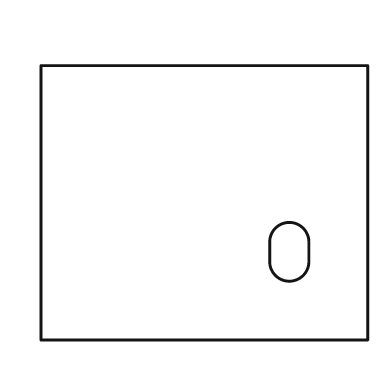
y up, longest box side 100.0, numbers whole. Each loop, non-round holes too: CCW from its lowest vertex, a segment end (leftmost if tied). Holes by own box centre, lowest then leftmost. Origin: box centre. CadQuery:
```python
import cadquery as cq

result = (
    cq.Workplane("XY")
    .moveTo(-50.0, -42.0)
    .lineTo(50.0, -42.0)
    .lineTo(50.0, 42.0)
    .lineTo(-50.0, 42.0)
    .close()
    .moveTo(20.0, -18.0)
    .threePointArc((26.0, -24.0), (32.0, -18.0))
    .lineTo(32.0, -12.0)
    .threePointArc((26.0, -6.0), (20.0, -12.0))
    .close()
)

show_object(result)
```